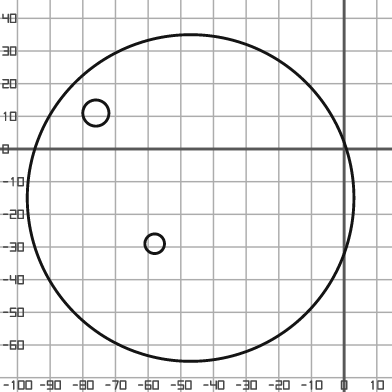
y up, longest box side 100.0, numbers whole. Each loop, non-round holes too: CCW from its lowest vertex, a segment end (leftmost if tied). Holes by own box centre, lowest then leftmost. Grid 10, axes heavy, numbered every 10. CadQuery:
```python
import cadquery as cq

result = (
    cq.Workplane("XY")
    .moveTo(-47.0, -15.0)
    .circle(50.0)
    .moveTo(-58.0, -29.0)
    .circle(3.0)
    .moveTo(-76.0, 11.0)
    .circle(4.0)
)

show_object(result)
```